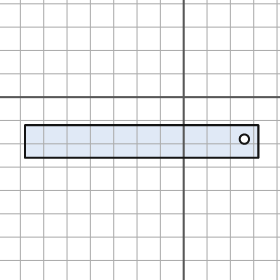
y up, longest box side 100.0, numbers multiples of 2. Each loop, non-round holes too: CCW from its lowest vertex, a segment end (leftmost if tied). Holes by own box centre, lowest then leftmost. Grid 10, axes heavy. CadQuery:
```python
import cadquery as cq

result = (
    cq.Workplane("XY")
    .moveTo(-68.0, -26.0)
    .lineTo(32.0, -26.0)
    .lineTo(32.0, -12.0)
    .lineTo(-68.0, -12.0)
    .close()
    .moveTo(26.0, -18.0)
    .circle(2.0)
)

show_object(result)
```